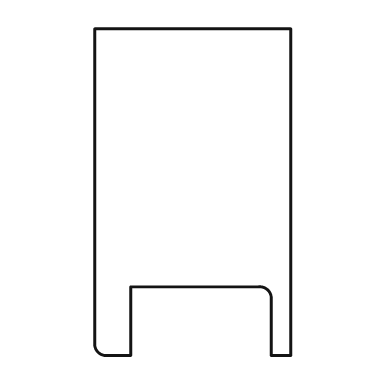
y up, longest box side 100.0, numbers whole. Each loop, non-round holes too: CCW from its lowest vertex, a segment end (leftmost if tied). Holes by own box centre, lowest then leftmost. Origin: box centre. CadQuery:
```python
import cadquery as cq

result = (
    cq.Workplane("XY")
    .moveTo(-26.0, -50.0)
    .lineTo(-19.0, -50.0)
    .lineTo(-19.0, -29.0)
    .lineTo(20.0, -29.0)
    .threePointArc((23.0, -30.0), (24.0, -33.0))
    .lineTo(24.0, -50.0)
    .lineTo(30.0, -50.0)
    .lineTo(30.0, 50.0)
    .lineTo(-30.0, 50.0)
    .lineTo(-30.0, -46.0)
    .threePointArc((-29.0, -49.0), (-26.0, -50.0))
    .close()
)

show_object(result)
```